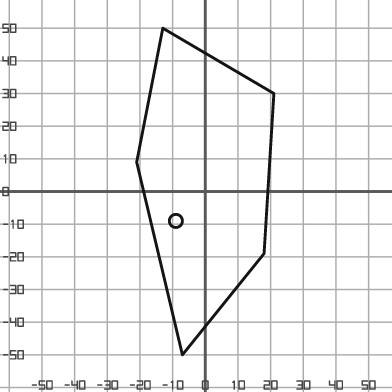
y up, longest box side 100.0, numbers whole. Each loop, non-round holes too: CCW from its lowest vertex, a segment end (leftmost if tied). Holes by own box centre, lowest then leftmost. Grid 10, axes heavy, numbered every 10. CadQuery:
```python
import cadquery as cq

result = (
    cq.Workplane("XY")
    .moveTo(-7.0, -50.0)
    .lineTo(18.0, -19.0)
    .lineTo(21.0, 30.0)
    .lineTo(-13.0, 50.0)
    .lineTo(-21.0, 9.0)
    .close()
    .moveTo(-9.0, -9.0)
    .circle(2.0)
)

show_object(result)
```